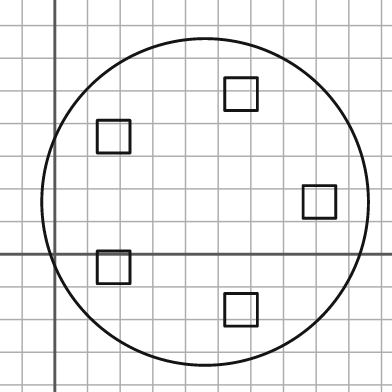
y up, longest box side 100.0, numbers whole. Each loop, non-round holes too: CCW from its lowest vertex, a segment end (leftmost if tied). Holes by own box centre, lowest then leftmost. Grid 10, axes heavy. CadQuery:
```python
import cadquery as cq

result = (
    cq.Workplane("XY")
    .moveTo(46.0, 16.0)
    .circle(50.0)
    .moveTo(52.0, -22.0)
    .lineTo(62.0, -22.0)
    .lineTo(62.0, -12.0)
    .lineTo(52.0, -12.0)
    .close()
    .moveTo(13.0, -9.0)
    .lineTo(23.0, -9.0)
    .lineTo(23.0, 1.0)
    .lineTo(13.0, 1.0)
    .close()
    .moveTo(76.0, 11.0)
    .lineTo(86.0, 11.0)
    .lineTo(86.0, 21.0)
    .lineTo(76.0, 21.0)
    .close()
    .moveTo(13.0, 31.0)
    .lineTo(23.0, 31.0)
    .lineTo(23.0, 41.0)
    .lineTo(13.0, 41.0)
    .close()
    .moveTo(52.0, 44.0)
    .lineTo(62.0, 44.0)
    .lineTo(62.0, 54.0)
    .lineTo(52.0, 54.0)
    .close()
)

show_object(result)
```